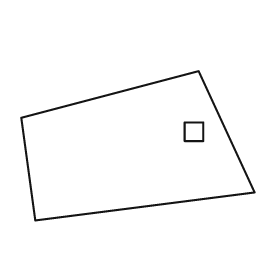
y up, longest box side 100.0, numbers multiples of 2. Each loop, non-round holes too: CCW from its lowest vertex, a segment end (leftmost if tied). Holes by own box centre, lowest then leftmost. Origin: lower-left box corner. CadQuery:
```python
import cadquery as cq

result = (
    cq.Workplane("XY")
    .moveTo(6.0, 0.0)
    .lineTo(100.0, 12.0)
    .lineTo(76.0, 64.0)
    .lineTo(0.0, 44.0)
    .close()
    .moveTo(70.0, 34.0)
    .lineTo(78.0, 34.0)
    .lineTo(78.0, 42.0)
    .lineTo(70.0, 42.0)
    .close()
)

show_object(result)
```